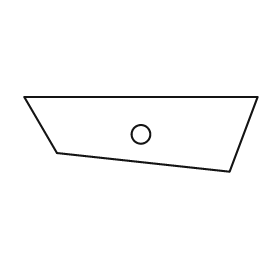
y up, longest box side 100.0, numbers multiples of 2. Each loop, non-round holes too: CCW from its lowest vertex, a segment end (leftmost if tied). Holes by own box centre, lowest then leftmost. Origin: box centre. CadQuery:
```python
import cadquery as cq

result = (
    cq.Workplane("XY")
    .moveTo(38.0, -16.0)
    .lineTo(50.0, 16.0)
    .lineTo(-50.0, 16.0)
    .lineTo(-36.0, -8.0)
    .close()
    .moveTo(0.0, 0.0)
    .circle(4.0)
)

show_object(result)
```